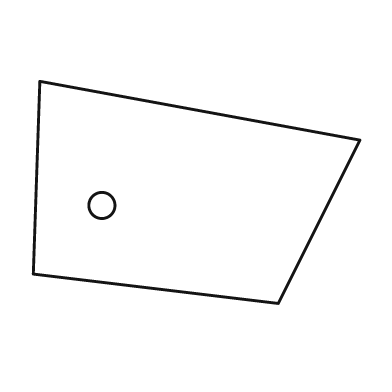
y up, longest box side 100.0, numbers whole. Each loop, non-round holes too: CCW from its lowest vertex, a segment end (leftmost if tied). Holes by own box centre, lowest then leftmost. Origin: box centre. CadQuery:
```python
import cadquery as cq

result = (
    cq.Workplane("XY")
    .moveTo(25.0, -34.0)
    .lineTo(50.0, 16.0)
    .lineTo(-48.0, 34.0)
    .lineTo(-50.0, -25.0)
    .close()
    .moveTo(-29.0, -4.0)
    .circle(4.0)
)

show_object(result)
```